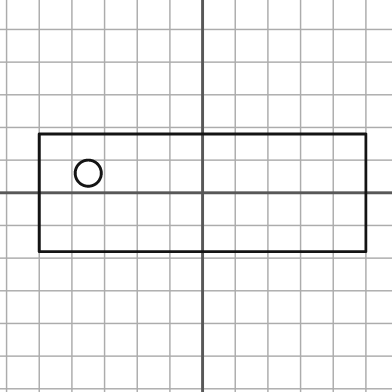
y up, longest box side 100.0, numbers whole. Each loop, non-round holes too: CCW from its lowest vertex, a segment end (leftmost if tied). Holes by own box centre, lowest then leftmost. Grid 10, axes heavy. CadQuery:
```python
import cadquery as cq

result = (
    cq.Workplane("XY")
    .moveTo(-50.0, -18.0)
    .lineTo(50.0, -18.0)
    .lineTo(50.0, 18.0)
    .lineTo(-50.0, 18.0)
    .close()
    .moveTo(-35.0, 6.0)
    .circle(4.0)
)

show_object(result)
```